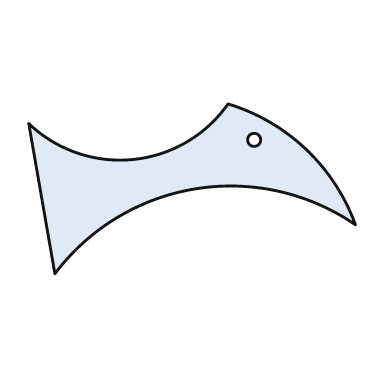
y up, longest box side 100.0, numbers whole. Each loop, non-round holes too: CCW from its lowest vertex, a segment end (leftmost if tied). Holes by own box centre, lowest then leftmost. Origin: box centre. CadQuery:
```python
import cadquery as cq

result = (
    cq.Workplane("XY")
    .moveTo(-42.0, -26.0)
    .threePointArc((1.0, 0.0), (50.0, -11.0))
    .threePointArc((35.0, 12.0), (11.0, 26.0))
    .threePointArc((-18.0, 9.0), (-50.0, 20.0))
    .close()
    .moveTo(19.0, 15.0)
    .circle(2.0)
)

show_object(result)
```